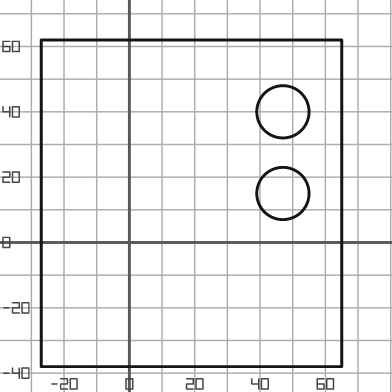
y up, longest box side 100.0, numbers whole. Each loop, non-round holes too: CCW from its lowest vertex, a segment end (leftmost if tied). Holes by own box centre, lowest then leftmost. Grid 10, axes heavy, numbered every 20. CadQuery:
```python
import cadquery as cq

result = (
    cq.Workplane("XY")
    .moveTo(-27.0, -38.0)
    .lineTo(65.0, -38.0)
    .lineTo(65.0, 62.0)
    .lineTo(-27.0, 62.0)
    .close()
    .moveTo(47.0, 15.0)
    .circle(8.0)
    .moveTo(47.0, 40.0)
    .circle(8.0)
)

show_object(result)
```